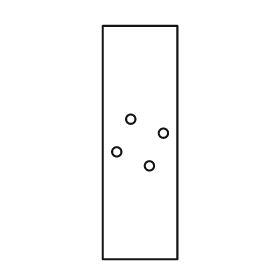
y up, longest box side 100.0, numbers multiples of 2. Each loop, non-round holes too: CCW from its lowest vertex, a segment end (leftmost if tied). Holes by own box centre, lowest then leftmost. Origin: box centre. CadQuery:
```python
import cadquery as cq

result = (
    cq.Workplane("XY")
    .moveTo(-16.0, -50.0)
    .lineTo(16.0, -50.0)
    .lineTo(16.0, 50.0)
    .lineTo(-16.0, 50.0)
    .close()
    .moveTo(4.0, -10.0)
    .circle(2.0)
    .moveTo(-10.0, -4.0)
    .circle(2.0)
    .moveTo(10.0, 4.0)
    .circle(2.0)
    .moveTo(-4.0, 10.0)
    .circle(2.0)
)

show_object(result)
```